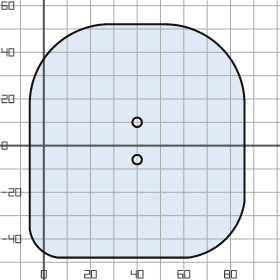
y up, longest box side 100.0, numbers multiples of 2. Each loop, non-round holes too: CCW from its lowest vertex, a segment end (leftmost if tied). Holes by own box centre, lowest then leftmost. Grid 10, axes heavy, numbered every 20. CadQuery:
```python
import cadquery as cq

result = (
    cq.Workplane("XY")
    .moveTo(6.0, -48.0)
    .lineTo(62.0, -48.0)
    .threePointArc((78.0, -40.0), (86.0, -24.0))
    .lineTo(86.0, 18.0)
    .threePointArc((76.0, 42.0), (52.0, 52.0))
    .lineTo(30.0, 52.0)
    .threePointArc((4.0, 42.0), (-6.0, 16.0))
    .lineTo(-6.0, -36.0)
    .threePointArc((-2.0, -44.0), (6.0, -48.0))
    .close()
    .moveTo(40.0, -6.0)
    .circle(2.0)
    .moveTo(40.0, 10.0)
    .circle(2.0)
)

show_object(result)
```